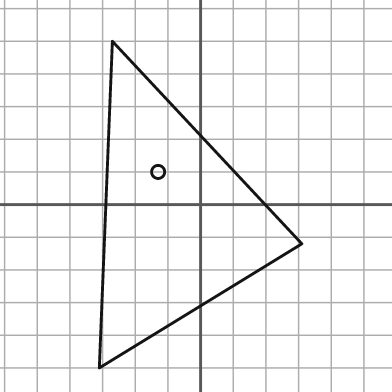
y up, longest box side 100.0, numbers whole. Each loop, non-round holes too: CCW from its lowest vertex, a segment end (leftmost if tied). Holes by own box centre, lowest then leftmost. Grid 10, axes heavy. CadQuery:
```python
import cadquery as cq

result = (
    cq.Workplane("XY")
    .moveTo(-31.0, -50.0)
    .lineTo(31.0, -12.0)
    .lineTo(-27.0, 50.0)
    .close()
    .moveTo(-13.0, 10.0)
    .circle(2.0)
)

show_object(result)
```